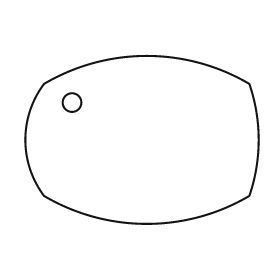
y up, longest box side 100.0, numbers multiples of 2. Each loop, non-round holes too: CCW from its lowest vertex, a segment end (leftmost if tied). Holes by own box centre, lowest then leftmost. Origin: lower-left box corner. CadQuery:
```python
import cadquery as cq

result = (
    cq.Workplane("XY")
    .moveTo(8.0, 12.0)
    .threePointArc((52.0, 0.0), (96.0, 12.0))
    .threePointArc((100.0, 36.0), (96.0, 60.0))
    .threePointArc((52.0, 72.0), (8.0, 60.0))
    .threePointArc((0.0, 36.0), (8.0, 12.0))
    .close()
    .moveTo(20.0, 52.0)
    .circle(4.0)
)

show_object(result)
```